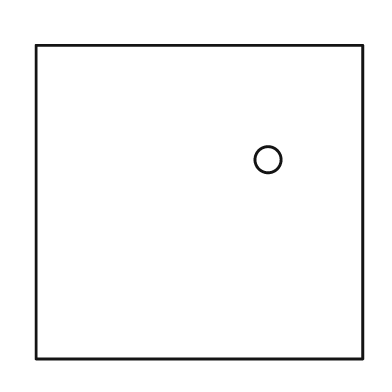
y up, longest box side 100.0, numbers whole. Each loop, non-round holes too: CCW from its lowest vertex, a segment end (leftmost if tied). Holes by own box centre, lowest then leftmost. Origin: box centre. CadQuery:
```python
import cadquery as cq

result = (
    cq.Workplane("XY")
    .moveTo(-50.0, -48.0)
    .lineTo(50.0, -48.0)
    .lineTo(50.0, 48.0)
    .lineTo(-50.0, 48.0)
    .close()
    .moveTo(21.0, 13.0)
    .circle(4.0)
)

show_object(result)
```